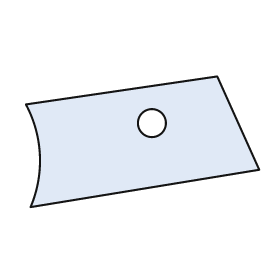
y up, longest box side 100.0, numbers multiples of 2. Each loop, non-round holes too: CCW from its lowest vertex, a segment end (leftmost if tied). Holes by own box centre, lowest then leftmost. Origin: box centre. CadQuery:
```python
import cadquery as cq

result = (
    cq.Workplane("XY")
    .moveTo(-48.0, -28.0)
    .lineTo(50.0, -12.0)
    .lineTo(32.0, 28.0)
    .lineTo(-50.0, 16.0)
    .threePointArc((-44.0, -6.0), (-48.0, -28.0))
    .close()
    .moveTo(4.0, 8.0)
    .circle(6.0)
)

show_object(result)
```